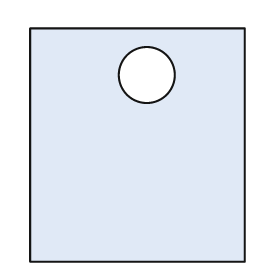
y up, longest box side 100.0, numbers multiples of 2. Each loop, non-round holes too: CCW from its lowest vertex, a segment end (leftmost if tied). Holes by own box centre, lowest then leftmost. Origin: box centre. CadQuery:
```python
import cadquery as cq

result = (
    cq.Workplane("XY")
    .moveTo(-46.0, -50.0)
    .lineTo(46.0, -50.0)
    .lineTo(46.0, 50.0)
    .lineTo(-46.0, 50.0)
    .close()
    .moveTo(4.0, 30.0)
    .circle(12.0)
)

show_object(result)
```